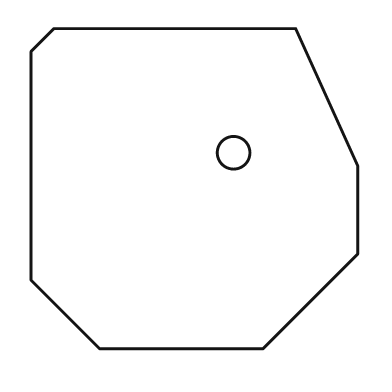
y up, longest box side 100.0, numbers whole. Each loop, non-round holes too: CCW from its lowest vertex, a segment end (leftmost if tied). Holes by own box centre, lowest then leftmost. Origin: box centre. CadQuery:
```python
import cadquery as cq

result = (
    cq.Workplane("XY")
    .moveTo(-29.0, -49.0)
    .lineTo(21.0, -49.0)
    .lineTo(50.0, -20.0)
    .lineTo(50.0, 7.0)
    .lineTo(31.0, 49.0)
    .lineTo(-43.0, 49.0)
    .lineTo(-50.0, 42.0)
    .lineTo(-50.0, -28.0)
    .close()
    .moveTo(12.0, 11.0)
    .circle(5.0)
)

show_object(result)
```